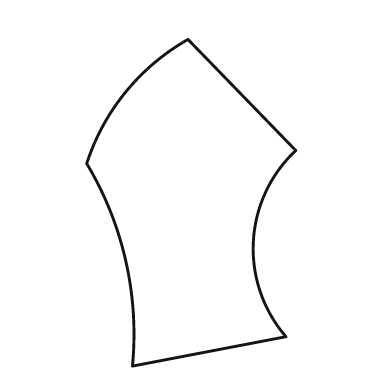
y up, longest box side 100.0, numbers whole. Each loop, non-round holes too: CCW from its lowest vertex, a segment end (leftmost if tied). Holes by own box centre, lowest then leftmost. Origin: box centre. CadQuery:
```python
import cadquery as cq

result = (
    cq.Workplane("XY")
    .moveTo(-18.0, -50.0)
    .lineTo(29.0, -41.0)
    .threePointArc((19.0, -12.0), (32.0, 16.0))
    .lineTo(-1.0, 50.0)
    .threePointArc((-20.0, 34.0), (-32.0, 12.0))
    .threePointArc((-20.0, -18.0), (-18.0, -50.0))
    .close()
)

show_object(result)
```